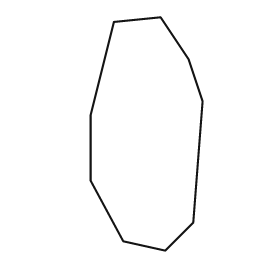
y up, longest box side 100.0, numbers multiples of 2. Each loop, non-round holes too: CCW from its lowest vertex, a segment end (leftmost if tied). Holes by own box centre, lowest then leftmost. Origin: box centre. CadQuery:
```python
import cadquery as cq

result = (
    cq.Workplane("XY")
    .moveTo(8.0, -50.0)
    .lineTo(20.0, -38.0)
    .lineTo(24.0, 14.0)
    .lineTo(18.0, 32.0)
    .lineTo(6.0, 50.0)
    .lineTo(-14.0, 48.0)
    .lineTo(-24.0, 8.0)
    .lineTo(-24.0, -20.0)
    .lineTo(-10.0, -46.0)
    .close()
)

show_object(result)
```